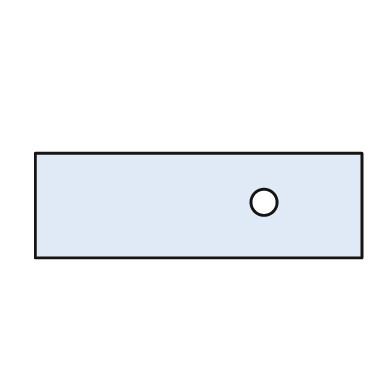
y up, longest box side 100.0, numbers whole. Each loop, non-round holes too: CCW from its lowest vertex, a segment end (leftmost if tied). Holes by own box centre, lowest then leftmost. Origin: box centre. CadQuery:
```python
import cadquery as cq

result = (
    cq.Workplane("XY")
    .moveTo(-50.0, -16.0)
    .lineTo(50.0, -16.0)
    .lineTo(50.0, 16.0)
    .lineTo(-50.0, 16.0)
    .close()
    .moveTo(20.0, 1.0)
    .circle(4.0)
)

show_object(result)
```